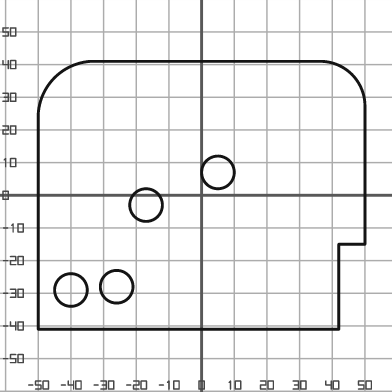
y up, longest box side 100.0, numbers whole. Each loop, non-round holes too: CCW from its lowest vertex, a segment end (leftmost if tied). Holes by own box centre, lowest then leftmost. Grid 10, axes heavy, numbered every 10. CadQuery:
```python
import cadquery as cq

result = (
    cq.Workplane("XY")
    .moveTo(-50.0, -41.0)
    .lineTo(42.0, -41.0)
    .lineTo(42.0, -15.0)
    .lineTo(50.0, -15.0)
    .lineTo(50.0, 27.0)
    .threePointArc((46.0, 37.0), (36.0, 41.0))
    .lineTo(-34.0, 41.0)
    .threePointArc((-45.0, 36.0), (-50.0, 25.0))
    .close()
    .moveTo(-40.0, -29.0)
    .circle(5.0)
    .moveTo(-26.0, -28.0)
    .circle(5.0)
    .moveTo(-17.0, -3.0)
    .circle(5.0)
    .moveTo(5.0, 7.0)
    .circle(5.0)
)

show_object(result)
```